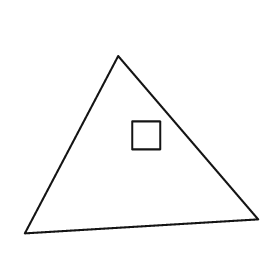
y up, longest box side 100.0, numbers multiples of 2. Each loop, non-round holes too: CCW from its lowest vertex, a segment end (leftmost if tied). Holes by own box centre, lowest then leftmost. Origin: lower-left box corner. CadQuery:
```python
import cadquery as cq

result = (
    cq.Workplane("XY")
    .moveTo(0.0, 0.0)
    .lineTo(100.0, 6.0)
    .lineTo(40.0, 76.0)
    .close()
    .moveTo(46.0, 36.0)
    .lineTo(58.0, 36.0)
    .lineTo(58.0, 48.0)
    .lineTo(46.0, 48.0)
    .close()
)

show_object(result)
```